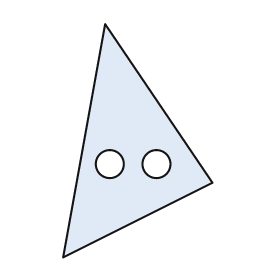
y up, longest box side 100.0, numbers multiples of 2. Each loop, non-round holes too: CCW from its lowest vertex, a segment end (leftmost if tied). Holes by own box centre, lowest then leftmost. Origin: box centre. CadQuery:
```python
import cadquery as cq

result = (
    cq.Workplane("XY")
    .moveTo(-32.0, -50.0)
    .lineTo(32.0, -18.0)
    .lineTo(-14.0, 50.0)
    .close()
    .moveTo(-12.0, -10.0)
    .circle(6.0)
    .moveTo(8.0, -10.0)
    .circle(6.0)
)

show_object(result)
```